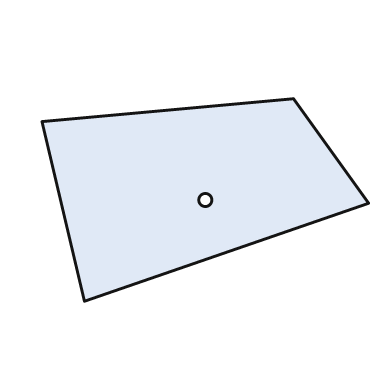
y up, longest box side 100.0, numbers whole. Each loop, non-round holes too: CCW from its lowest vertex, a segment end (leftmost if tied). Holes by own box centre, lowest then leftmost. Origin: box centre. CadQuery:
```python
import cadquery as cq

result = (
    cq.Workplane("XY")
    .moveTo(-37.0, -31.0)
    .lineTo(50.0, -1.0)
    .lineTo(27.0, 31.0)
    .lineTo(-50.0, 24.0)
    .close()
    .moveTo(0.0, 0.0)
    .circle(2.0)
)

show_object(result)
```